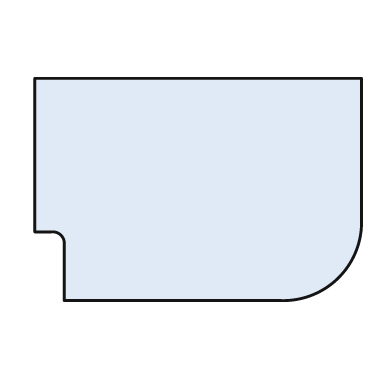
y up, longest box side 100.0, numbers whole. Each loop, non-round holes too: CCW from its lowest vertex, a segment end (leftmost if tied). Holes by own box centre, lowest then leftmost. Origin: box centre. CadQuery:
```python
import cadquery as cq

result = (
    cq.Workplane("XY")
    .moveTo(-41.0, -34.0)
    .lineTo(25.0, -34.0)
    .threePointArc((43.0, -27.0), (50.0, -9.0))
    .lineTo(50.0, 34.0)
    .lineTo(-50.0, 34.0)
    .lineTo(-50.0, -13.0)
    .lineTo(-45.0, -13.0)
    .threePointArc((-42.0, -14.0), (-41.0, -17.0))
    .close()
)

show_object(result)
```